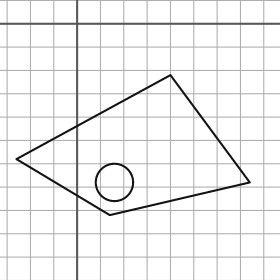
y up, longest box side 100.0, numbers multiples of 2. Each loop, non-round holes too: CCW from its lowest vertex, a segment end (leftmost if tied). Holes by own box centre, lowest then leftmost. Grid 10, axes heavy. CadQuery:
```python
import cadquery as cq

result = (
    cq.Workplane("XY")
    .moveTo(14.0, -82.0)
    .lineTo(74.0, -68.0)
    .lineTo(40.0, -22.0)
    .lineTo(-26.0, -58.0)
    .close()
    .moveTo(16.0, -68.0)
    .circle(8.0)
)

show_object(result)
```